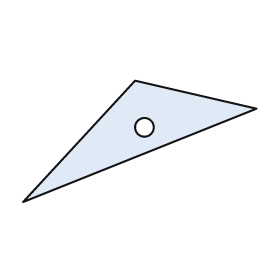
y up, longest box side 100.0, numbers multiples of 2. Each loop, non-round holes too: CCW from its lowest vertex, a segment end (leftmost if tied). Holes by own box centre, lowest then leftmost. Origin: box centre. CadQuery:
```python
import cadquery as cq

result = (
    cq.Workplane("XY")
    .moveTo(-50.0, -26.0)
    .lineTo(50.0, 14.0)
    .lineTo(-2.0, 26.0)
    .close()
    .moveTo(2.0, 6.0)
    .circle(4.0)
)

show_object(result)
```